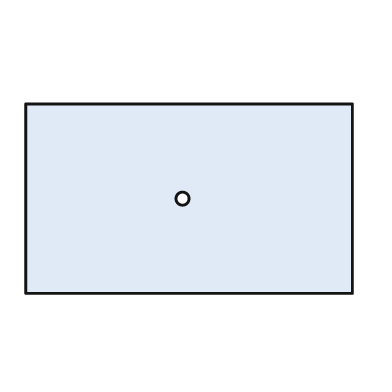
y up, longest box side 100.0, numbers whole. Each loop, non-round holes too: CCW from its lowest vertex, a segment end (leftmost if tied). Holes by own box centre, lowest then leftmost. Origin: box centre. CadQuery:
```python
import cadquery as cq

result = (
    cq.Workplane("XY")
    .moveTo(-50.0, -29.0)
    .lineTo(50.0, -29.0)
    .lineTo(50.0, 29.0)
    .lineTo(-50.0, 29.0)
    .close()
    .moveTo(-2.0, 0.0)
    .circle(2.0)
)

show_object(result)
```